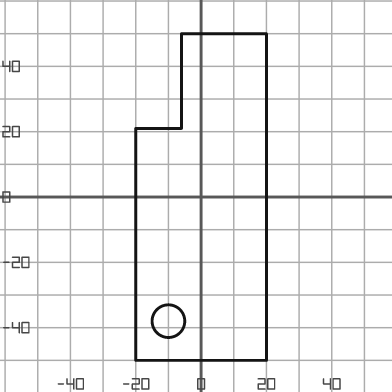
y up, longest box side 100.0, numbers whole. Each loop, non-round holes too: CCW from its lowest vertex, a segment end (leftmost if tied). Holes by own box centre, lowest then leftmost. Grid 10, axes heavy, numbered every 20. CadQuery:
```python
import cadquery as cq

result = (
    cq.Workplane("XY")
    .moveTo(-20.0, -50.0)
    .lineTo(20.0, -50.0)
    .lineTo(20.0, 50.0)
    .lineTo(-6.0, 50.0)
    .lineTo(-6.0, 21.0)
    .lineTo(-20.0, 21.0)
    .close()
    .moveTo(-10.0, -38.0)
    .circle(5.0)
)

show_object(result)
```